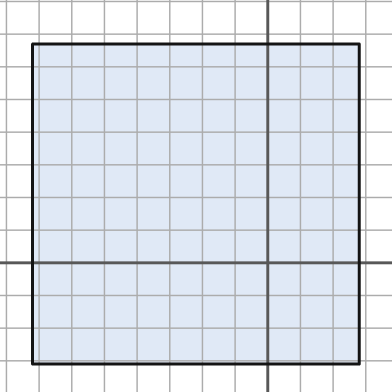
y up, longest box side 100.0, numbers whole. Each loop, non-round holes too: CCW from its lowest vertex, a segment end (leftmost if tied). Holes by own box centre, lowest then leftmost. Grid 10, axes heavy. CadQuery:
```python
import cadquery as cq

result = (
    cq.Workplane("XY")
    .moveTo(-72.0, -31.0)
    .lineTo(28.0, -31.0)
    .lineTo(28.0, 67.0)
    .lineTo(-72.0, 67.0)
    .close()
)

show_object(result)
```